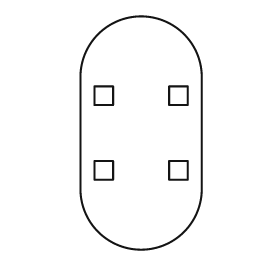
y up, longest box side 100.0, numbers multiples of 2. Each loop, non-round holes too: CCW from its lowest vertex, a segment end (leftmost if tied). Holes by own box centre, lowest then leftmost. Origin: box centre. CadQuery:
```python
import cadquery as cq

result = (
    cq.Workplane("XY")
    .moveTo(-26.0, -24.0)
    .threePointArc((0.0, -50.0), (26.0, -24.0))
    .lineTo(26.0, 24.0)
    .threePointArc((0.0, 50.0), (-26.0, 24.0))
    .close()
    .moveTo(-20.0, -20.0)
    .lineTo(-12.0, -20.0)
    .lineTo(-12.0, -12.0)
    .lineTo(-20.0, -12.0)
    .close()
    .moveTo(12.0, -20.0)
    .lineTo(20.0, -20.0)
    .lineTo(20.0, -12.0)
    .lineTo(12.0, -12.0)
    .close()
    .moveTo(-20.0, 12.0)
    .lineTo(-12.0, 12.0)
    .lineTo(-12.0, 20.0)
    .lineTo(-20.0, 20.0)
    .close()
    .moveTo(12.0, 12.0)
    .lineTo(20.0, 12.0)
    .lineTo(20.0, 20.0)
    .lineTo(12.0, 20.0)
    .close()
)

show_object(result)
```